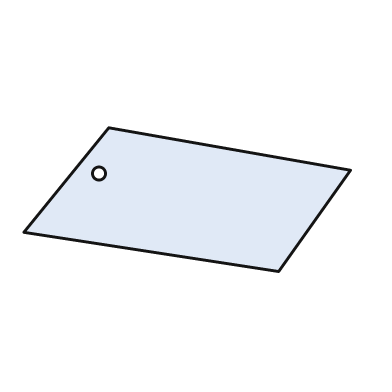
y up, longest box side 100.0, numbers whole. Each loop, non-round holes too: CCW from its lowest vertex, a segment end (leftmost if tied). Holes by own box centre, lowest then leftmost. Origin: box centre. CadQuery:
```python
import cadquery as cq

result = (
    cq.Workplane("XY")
    .moveTo(28.0, -22.0)
    .lineTo(50.0, 9.0)
    .lineTo(-24.0, 22.0)
    .lineTo(-50.0, -10.0)
    .close()
    .moveTo(-27.0, 8.0)
    .circle(2.0)
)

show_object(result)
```